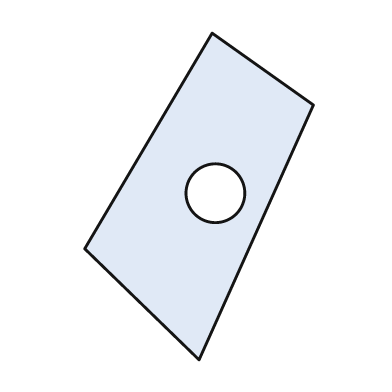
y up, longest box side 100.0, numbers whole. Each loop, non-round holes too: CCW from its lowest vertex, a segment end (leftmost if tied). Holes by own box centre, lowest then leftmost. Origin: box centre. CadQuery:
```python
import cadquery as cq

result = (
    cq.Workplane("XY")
    .moveTo(0.0, -50.0)
    .lineTo(35.0, 28.0)
    .lineTo(4.0, 50.0)
    .lineTo(-35.0, -16.0)
    .close()
    .moveTo(5.0, 1.0)
    .circle(9.0)
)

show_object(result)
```